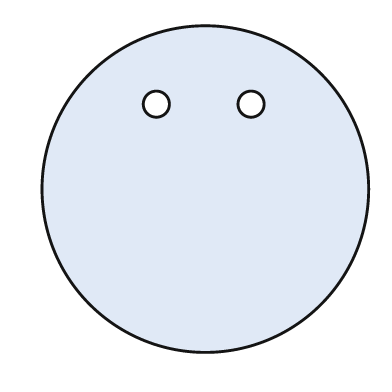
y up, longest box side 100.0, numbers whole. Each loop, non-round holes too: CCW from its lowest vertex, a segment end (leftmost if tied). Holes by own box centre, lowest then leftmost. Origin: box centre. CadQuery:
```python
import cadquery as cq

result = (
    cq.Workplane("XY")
    .moveTo(0.0, 0.0)
    .circle(50.0)
    .moveTo(-15.0, 26.0)
    .circle(4.0)
    .moveTo(14.0, 26.0)
    .circle(4.0)
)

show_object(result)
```